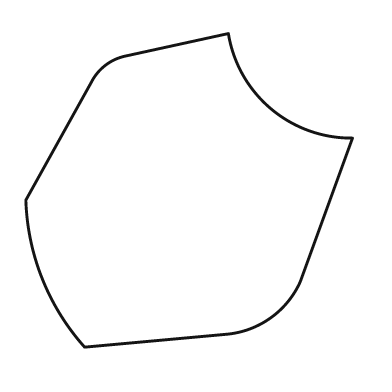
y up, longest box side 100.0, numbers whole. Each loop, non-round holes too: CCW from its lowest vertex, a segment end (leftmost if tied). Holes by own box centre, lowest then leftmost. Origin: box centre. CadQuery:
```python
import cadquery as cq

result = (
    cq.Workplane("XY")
    .moveTo(-32.0, -48.0)
    .lineTo(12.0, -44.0)
    .threePointArc((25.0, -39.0), (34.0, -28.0))
    .lineTo(50.0, 16.0)
    .threePointArc((25.0, 25.0), (12.0, 48.0))
    .lineTo(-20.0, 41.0)
    .threePointArc((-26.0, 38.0), (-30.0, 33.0))
    .lineTo(-50.0, -3.0)
    .threePointArc((-45.0, -27.0), (-32.0, -48.0))
    .close()
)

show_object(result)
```